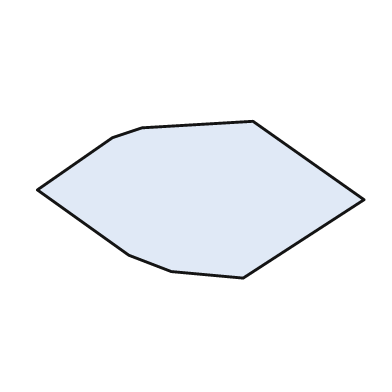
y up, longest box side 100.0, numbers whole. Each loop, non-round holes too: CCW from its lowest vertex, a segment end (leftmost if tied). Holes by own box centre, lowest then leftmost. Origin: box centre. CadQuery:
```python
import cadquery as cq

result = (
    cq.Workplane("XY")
    .moveTo(13.0, -24.0)
    .lineTo(50.0, 0.0)
    .lineTo(16.0, 24.0)
    .lineTo(-18.0, 22.0)
    .lineTo(-27.0, 19.0)
    .lineTo(-50.0, 3.0)
    .lineTo(-22.0, -17.0)
    .lineTo(-9.0, -22.0)
    .close()
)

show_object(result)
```